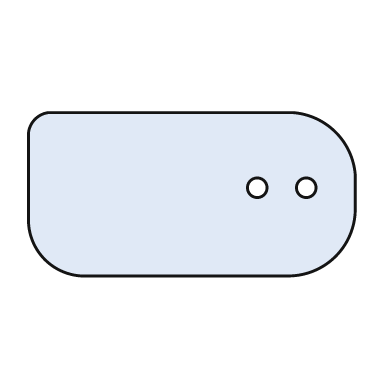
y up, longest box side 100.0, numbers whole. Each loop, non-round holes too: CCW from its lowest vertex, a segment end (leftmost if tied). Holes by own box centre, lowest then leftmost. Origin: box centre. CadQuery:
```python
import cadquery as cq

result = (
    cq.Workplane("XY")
    .moveTo(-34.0, -25.0)
    .lineTo(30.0, -25.0)
    .threePointArc((44.0, -19.0), (50.0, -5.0))
    .lineTo(50.0, 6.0)
    .threePointArc((44.0, 19.0), (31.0, 25.0))
    .lineTo(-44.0, 25.0)
    .threePointArc((-48.0, 23.0), (-50.0, 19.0))
    .lineTo(-50.0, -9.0)
    .threePointArc((-45.0, -20.0), (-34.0, -25.0))
    .close()
    .moveTo(20.0, 2.0)
    .circle(3.0)
    .moveTo(35.0, 2.0)
    .circle(3.0)
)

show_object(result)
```